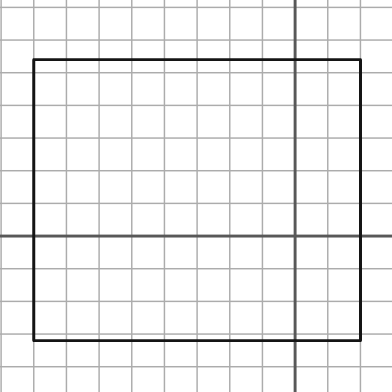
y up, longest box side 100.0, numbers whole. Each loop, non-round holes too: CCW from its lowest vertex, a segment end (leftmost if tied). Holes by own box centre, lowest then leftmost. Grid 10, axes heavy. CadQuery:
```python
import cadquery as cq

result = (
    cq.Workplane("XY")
    .moveTo(-80.0, -32.0)
    .lineTo(20.0, -32.0)
    .lineTo(20.0, 54.0)
    .lineTo(-80.0, 54.0)
    .close()
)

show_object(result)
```